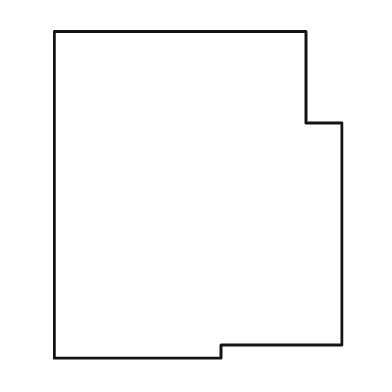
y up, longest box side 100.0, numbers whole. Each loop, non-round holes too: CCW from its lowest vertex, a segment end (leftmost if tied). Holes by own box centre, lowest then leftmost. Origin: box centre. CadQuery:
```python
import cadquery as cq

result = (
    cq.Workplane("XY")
    .moveTo(-44.0, -50.0)
    .lineTo(7.0, -50.0)
    .lineTo(7.0, -46.0)
    .lineTo(44.0, -46.0)
    .lineTo(44.0, 22.0)
    .lineTo(33.0, 22.0)
    .lineTo(33.0, 50.0)
    .lineTo(-44.0, 50.0)
    .close()
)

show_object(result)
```